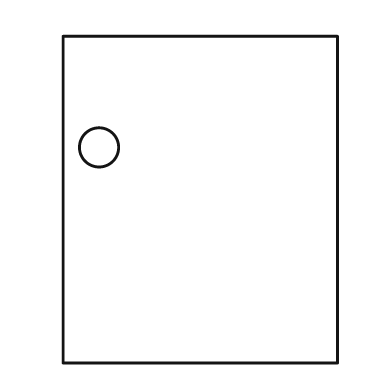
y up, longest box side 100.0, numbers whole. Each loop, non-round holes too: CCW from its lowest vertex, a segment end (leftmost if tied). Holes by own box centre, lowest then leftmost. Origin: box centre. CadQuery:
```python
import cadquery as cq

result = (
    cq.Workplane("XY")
    .moveTo(-42.0, -50.0)
    .lineTo(42.0, -50.0)
    .lineTo(42.0, 50.0)
    .lineTo(-42.0, 50.0)
    .close()
    .moveTo(-31.0, 16.0)
    .circle(6.0)
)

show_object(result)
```